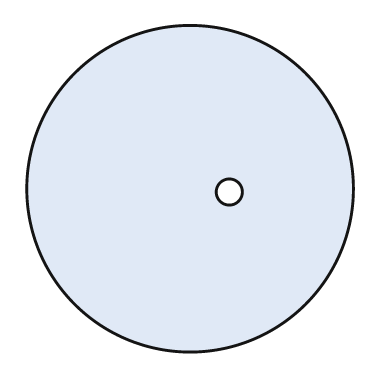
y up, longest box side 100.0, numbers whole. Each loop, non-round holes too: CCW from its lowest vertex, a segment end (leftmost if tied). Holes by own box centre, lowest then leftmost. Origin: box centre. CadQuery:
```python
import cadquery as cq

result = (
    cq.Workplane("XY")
    .moveTo(0.0, 0.0)
    .circle(50.0)
    .moveTo(12.0, -1.0)
    .circle(4.0)
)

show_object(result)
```